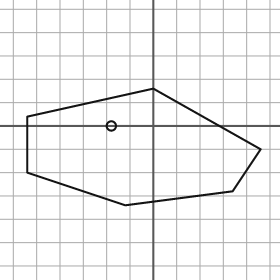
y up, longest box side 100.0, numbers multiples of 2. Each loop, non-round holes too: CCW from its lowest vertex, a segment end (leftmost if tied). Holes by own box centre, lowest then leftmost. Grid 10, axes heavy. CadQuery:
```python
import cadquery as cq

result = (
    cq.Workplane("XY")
    .moveTo(-12.0, -34.0)
    .lineTo(34.0, -28.0)
    .lineTo(46.0, -10.0)
    .lineTo(0.0, 16.0)
    .lineTo(-54.0, 4.0)
    .lineTo(-54.0, -20.0)
    .close()
    .moveTo(-18.0, 0.0)
    .circle(2.0)
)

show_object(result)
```